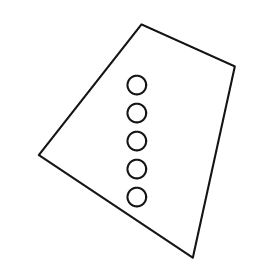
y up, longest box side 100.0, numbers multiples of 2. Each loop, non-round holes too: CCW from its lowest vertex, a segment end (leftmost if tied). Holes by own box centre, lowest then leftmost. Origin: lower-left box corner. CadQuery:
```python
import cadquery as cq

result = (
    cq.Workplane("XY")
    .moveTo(66.0, 0.0)
    .lineTo(84.0, 82.0)
    .lineTo(44.0, 100.0)
    .lineTo(0.0, 44.0)
    .close()
    .moveTo(42.0, 26.0)
    .circle(4.0)
    .moveTo(42.0, 38.0)
    .circle(4.0)
    .moveTo(42.0, 50.0)
    .circle(4.0)
    .moveTo(42.0, 62.0)
    .circle(4.0)
    .moveTo(42.0, 74.0)
    .circle(4.0)
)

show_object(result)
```